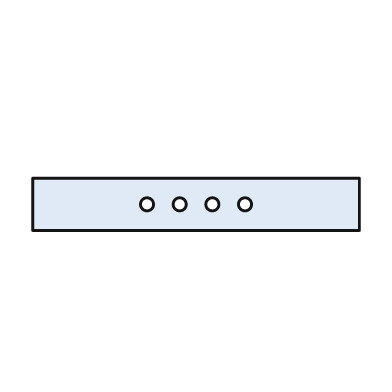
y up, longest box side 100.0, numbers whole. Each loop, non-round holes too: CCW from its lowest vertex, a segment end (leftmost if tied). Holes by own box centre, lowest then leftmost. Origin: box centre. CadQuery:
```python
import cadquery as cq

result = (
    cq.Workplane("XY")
    .moveTo(-50.0, -8.0)
    .lineTo(50.0, -8.0)
    .lineTo(50.0, 8.0)
    .lineTo(-50.0, 8.0)
    .close()
    .moveTo(-15.0, 0.0)
    .circle(2.0)
    .moveTo(-5.0, 0.0)
    .circle(2.0)
    .moveTo(5.0, 0.0)
    .circle(2.0)
    .moveTo(15.0, 0.0)
    .circle(2.0)
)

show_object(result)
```